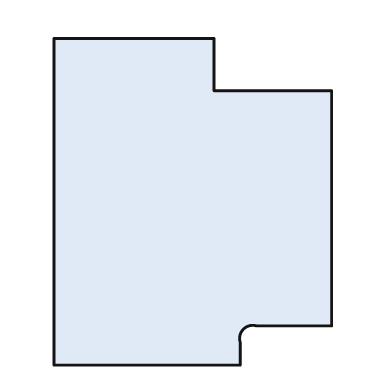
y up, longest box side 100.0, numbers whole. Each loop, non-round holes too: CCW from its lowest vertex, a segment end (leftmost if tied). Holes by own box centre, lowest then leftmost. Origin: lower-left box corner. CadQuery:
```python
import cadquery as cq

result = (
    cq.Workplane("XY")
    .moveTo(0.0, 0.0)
    .lineTo(57.0, 0.0)
    .lineTo(57.0, 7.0)
    .threePointArc((58.0, 11.0), (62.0, 12.0))
    .lineTo(85.0, 12.0)
    .lineTo(85.0, 84.0)
    .lineTo(49.0, 84.0)
    .lineTo(49.0, 100.0)
    .lineTo(0.0, 100.0)
    .close()
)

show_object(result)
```